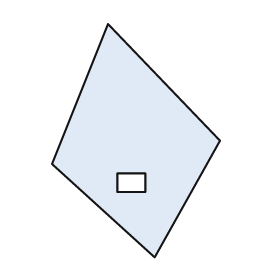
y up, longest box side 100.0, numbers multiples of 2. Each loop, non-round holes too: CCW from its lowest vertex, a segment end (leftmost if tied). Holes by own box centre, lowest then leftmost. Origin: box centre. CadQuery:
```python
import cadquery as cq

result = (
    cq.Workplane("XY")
    .moveTo(8.0, -50.0)
    .lineTo(36.0, 0.0)
    .lineTo(-12.0, 50.0)
    .lineTo(-36.0, -10.0)
    .close()
    .moveTo(-8.0, -22.0)
    .lineTo(4.0, -22.0)
    .lineTo(4.0, -14.0)
    .lineTo(-8.0, -14.0)
    .close()
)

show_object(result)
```